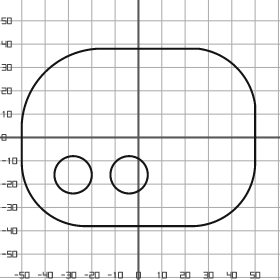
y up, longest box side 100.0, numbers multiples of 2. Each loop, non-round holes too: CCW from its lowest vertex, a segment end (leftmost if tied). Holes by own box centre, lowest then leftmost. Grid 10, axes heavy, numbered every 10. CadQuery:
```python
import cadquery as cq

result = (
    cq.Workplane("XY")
    .moveTo(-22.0, -38.0)
    .lineTo(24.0, -38.0)
    .threePointArc((42.0, -30.0), (50.0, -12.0))
    .lineTo(50.0, 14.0)
    .threePointArc((42.0, 30.0), (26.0, 38.0))
    .lineTo(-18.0, 38.0)
    .threePointArc((-40.0, 28.0), (-50.0, 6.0))
    .lineTo(-50.0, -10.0)
    .threePointArc((-42.0, -30.0), (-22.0, -38.0))
    .close()
    .moveTo(-28.0, -16.0)
    .circle(8.0)
    .moveTo(-4.0, -16.0)
    .circle(8.0)
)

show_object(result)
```